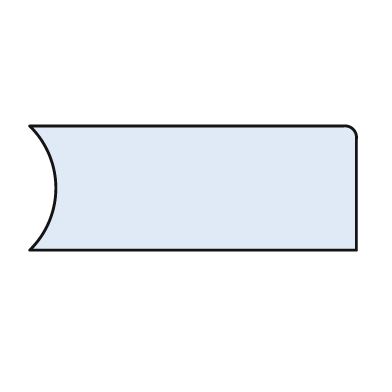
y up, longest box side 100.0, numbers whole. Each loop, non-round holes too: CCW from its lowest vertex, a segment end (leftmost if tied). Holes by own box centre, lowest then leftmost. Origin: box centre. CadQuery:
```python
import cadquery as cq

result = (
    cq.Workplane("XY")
    .moveTo(-50.0, -19.0)
    .lineTo(50.0, -19.0)
    .lineTo(50.0, 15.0)
    .threePointArc((49.0, 18.0), (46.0, 19.0))
    .lineTo(-50.0, 19.0)
    .threePointArc((-42.0, 0.0), (-50.0, -19.0))
    .close()
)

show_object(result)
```